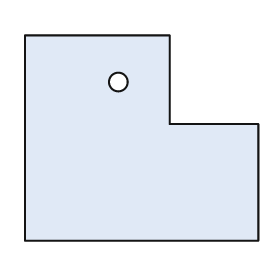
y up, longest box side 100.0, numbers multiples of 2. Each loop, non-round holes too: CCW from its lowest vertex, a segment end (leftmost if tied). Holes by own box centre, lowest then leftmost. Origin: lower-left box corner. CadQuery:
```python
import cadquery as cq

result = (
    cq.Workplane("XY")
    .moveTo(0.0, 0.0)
    .lineTo(100.0, 0.0)
    .lineTo(100.0, 50.0)
    .lineTo(62.0, 50.0)
    .lineTo(62.0, 88.0)
    .lineTo(0.0, 88.0)
    .close()
    .moveTo(40.0, 68.0)
    .circle(4.0)
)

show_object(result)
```